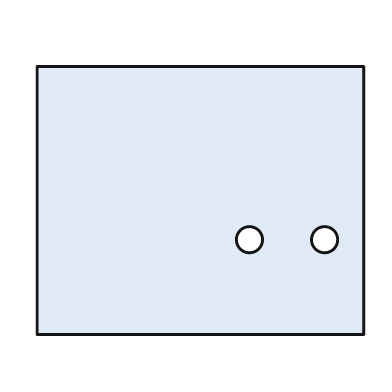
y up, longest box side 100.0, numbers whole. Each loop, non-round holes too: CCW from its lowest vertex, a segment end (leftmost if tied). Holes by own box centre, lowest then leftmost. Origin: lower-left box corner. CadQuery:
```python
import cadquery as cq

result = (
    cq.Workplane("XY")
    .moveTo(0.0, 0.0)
    .lineTo(100.0, 0.0)
    .lineTo(100.0, 82.0)
    .lineTo(0.0, 82.0)
    .close()
    .moveTo(65.0, 29.0)
    .circle(4.0)
    .moveTo(88.0, 29.0)
    .circle(4.0)
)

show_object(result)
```